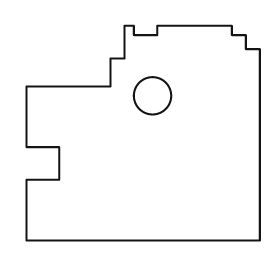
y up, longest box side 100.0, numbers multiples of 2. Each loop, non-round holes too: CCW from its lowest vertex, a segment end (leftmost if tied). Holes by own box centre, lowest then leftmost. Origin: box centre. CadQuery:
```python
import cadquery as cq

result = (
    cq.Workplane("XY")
    .moveTo(-50.0, -46.0)
    .lineTo(50.0, -46.0)
    .lineTo(50.0, 36.0)
    .lineTo(44.0, 36.0)
    .lineTo(44.0, 42.0)
    .lineTo(38.0, 42.0)
    .lineTo(38.0, 46.0)
    .lineTo(6.0, 46.0)
    .lineTo(6.0, 42.0)
    .lineTo(-4.0, 42.0)
    .lineTo(-4.0, 46.0)
    .lineTo(-8.0, 46.0)
    .lineTo(-8.0, 32.0)
    .lineTo(-14.0, 32.0)
    .lineTo(-14.0, 20.0)
    .lineTo(-50.0, 20.0)
    .lineTo(-50.0, -6.0)
    .lineTo(-36.0, -6.0)
    .lineTo(-36.0, -20.0)
    .lineTo(-50.0, -20.0)
    .close()
    .moveTo(4.0, 16.0)
    .circle(8.0)
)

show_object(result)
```